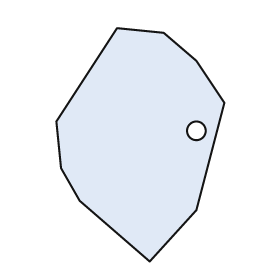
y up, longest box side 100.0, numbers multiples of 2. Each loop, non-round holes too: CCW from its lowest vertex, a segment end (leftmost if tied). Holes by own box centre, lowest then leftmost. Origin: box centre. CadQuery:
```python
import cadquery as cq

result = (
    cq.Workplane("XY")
    .moveTo(4.0, -50.0)
    .lineTo(24.0, -28.0)
    .lineTo(36.0, 18.0)
    .lineTo(24.0, 36.0)
    .lineTo(10.0, 48.0)
    .lineTo(-10.0, 50.0)
    .lineTo(-36.0, 10.0)
    .lineTo(-34.0, -10.0)
    .lineTo(-26.0, -24.0)
    .close()
    .moveTo(24.0, 6.0)
    .circle(4.0)
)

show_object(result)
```